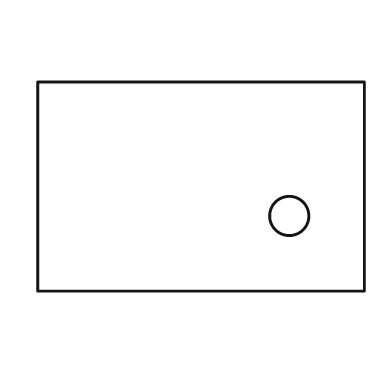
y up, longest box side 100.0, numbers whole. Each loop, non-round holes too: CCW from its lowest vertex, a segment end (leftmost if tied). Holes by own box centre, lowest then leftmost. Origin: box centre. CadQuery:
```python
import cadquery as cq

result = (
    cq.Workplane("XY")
    .moveTo(-50.0, -32.0)
    .lineTo(50.0, -32.0)
    .lineTo(50.0, 32.0)
    .lineTo(-50.0, 32.0)
    .close()
    .moveTo(27.0, -9.0)
    .circle(6.0)
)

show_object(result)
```